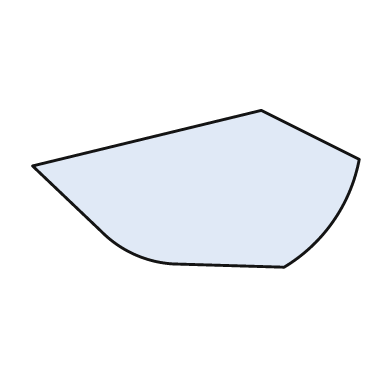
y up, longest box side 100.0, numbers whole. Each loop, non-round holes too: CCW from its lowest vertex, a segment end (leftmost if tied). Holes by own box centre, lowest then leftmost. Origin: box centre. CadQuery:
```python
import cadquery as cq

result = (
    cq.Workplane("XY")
    .moveTo(27.0, -24.0)
    .threePointArc((42.0, -10.0), (50.0, 9.0))
    .lineTo(20.0, 24.0)
    .lineTo(-50.0, 7.0)
    .lineTo(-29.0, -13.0)
    .threePointArc((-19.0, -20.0), (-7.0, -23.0))
    .close()
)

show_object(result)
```